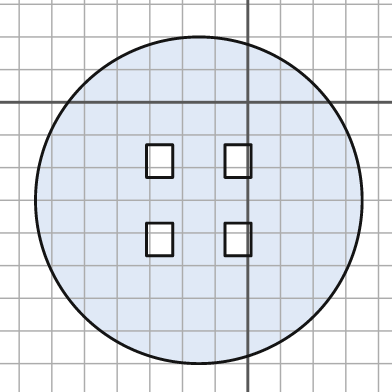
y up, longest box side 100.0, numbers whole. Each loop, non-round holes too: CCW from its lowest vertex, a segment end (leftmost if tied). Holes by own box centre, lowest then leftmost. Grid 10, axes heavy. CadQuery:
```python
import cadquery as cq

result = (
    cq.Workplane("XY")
    .moveTo(-15.0, -30.0)
    .circle(50.0)
    .moveTo(-31.0, -47.0)
    .lineTo(-23.0, -47.0)
    .lineTo(-23.0, -37.0)
    .lineTo(-31.0, -37.0)
    .close()
    .moveTo(-7.0, -47.0)
    .lineTo(1.0, -47.0)
    .lineTo(1.0, -37.0)
    .lineTo(-7.0, -37.0)
    .close()
    .moveTo(-31.0, -23.0)
    .lineTo(-23.0, -23.0)
    .lineTo(-23.0, -13.0)
    .lineTo(-31.0, -13.0)
    .close()
    .moveTo(-7.0, -23.0)
    .lineTo(1.0, -23.0)
    .lineTo(1.0, -13.0)
    .lineTo(-7.0, -13.0)
    .close()
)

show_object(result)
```